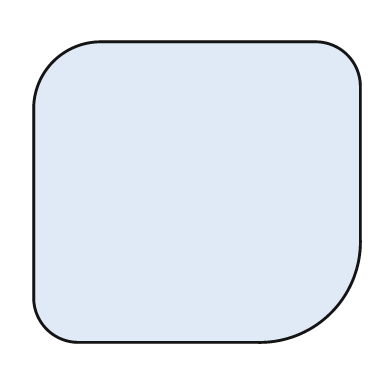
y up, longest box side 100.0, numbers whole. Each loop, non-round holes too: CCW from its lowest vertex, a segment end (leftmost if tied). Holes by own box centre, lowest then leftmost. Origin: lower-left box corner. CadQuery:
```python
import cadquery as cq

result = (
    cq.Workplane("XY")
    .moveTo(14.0, 0.0)
    .lineTo(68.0, 0.0)
    .threePointArc((91.0, 9.0), (100.0, 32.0))
    .lineTo(100.0, 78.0)
    .threePointArc((96.0, 88.0), (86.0, 92.0))
    .lineTo(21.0, 92.0)
    .threePointArc((6.0, 86.0), (0.0, 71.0))
    .lineTo(0.0, 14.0)
    .threePointArc((4.0, 4.0), (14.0, 0.0))
    .close()
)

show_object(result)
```